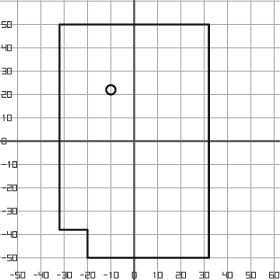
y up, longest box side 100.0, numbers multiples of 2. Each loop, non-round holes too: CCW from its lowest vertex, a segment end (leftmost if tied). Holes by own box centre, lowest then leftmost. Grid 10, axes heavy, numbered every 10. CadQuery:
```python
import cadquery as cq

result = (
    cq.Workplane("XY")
    .moveTo(-20.0, -50.0)
    .lineTo(32.0, -50.0)
    .lineTo(32.0, 50.0)
    .lineTo(-32.0, 50.0)
    .lineTo(-32.0, -38.0)
    .lineTo(-20.0, -38.0)
    .close()
    .moveTo(-10.0, 22.0)
    .circle(2.0)
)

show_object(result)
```